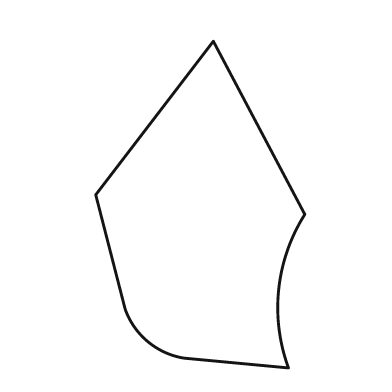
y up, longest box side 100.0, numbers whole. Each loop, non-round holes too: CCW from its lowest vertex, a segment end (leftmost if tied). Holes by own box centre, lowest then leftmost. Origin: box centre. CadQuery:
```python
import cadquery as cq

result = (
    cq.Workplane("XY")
    .moveTo(27.0, -50.0)
    .threePointArc((24.0, -26.0), (32.0, -3.0))
    .lineTo(4.0, 50.0)
    .lineTo(-32.0, 3.0)
    .lineTo(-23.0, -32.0)
    .threePointArc((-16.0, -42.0), (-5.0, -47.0))
    .close()
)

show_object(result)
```